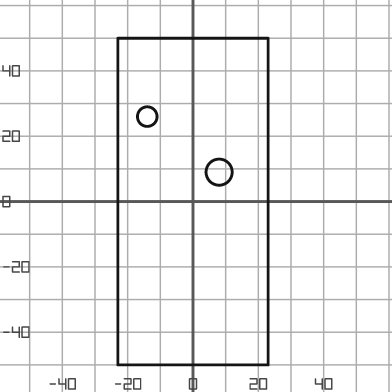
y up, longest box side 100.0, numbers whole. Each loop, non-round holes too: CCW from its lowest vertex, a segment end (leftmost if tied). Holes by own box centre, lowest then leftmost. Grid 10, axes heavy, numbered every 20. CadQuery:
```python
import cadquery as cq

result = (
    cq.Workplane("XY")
    .moveTo(-23.0, -50.0)
    .lineTo(23.0, -50.0)
    .lineTo(23.0, 50.0)
    .lineTo(-23.0, 50.0)
    .close()
    .moveTo(8.0, 9.0)
    .circle(4.0)
    .moveTo(-14.0, 26.0)
    .circle(3.0)
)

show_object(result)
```